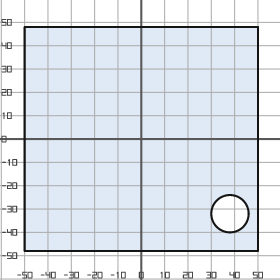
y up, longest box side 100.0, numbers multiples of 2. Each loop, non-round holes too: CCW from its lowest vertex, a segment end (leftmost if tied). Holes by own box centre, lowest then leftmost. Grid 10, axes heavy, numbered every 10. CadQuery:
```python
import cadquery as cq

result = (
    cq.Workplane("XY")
    .moveTo(-50.0, -48.0)
    .lineTo(50.0, -48.0)
    .lineTo(50.0, 48.0)
    .lineTo(-50.0, 48.0)
    .close()
    .moveTo(38.0, -32.0)
    .circle(8.0)
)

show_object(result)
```